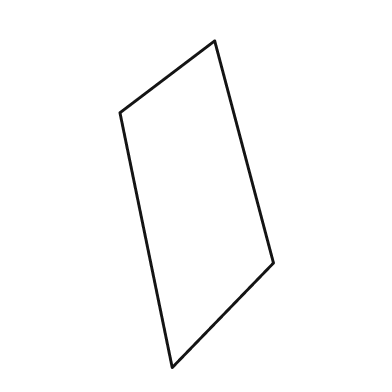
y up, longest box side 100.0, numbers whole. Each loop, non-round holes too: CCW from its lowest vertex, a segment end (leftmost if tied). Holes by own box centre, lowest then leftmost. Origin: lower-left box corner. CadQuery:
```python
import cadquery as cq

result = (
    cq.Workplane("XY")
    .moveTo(16.0, 0.0)
    .lineTo(47.0, 32.0)
    .lineTo(29.0, 100.0)
    .lineTo(0.0, 78.0)
    .close()
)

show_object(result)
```